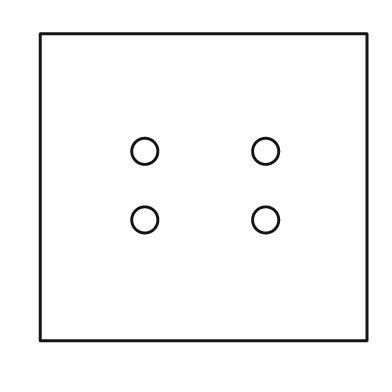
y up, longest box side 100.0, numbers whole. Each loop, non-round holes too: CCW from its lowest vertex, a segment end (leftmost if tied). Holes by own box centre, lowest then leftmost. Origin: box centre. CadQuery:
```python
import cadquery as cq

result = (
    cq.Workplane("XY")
    .moveTo(-50.0, -47.0)
    .lineTo(50.0, -47.0)
    .lineTo(50.0, 47.0)
    .lineTo(-50.0, 47.0)
    .close()
    .moveTo(-18.0, -10.0)
    .circle(4.0)
    .moveTo(19.0, -10.0)
    .circle(4.0)
    .moveTo(-18.0, 11.0)
    .circle(4.0)
    .moveTo(19.0, 11.0)
    .circle(4.0)
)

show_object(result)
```